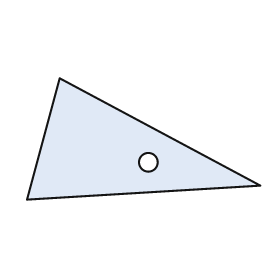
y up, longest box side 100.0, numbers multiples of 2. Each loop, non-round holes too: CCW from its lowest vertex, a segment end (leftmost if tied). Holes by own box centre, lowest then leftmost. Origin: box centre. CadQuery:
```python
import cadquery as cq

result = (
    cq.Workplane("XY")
    .moveTo(-50.0, -26.0)
    .lineTo(50.0, -20.0)
    .lineTo(-36.0, 26.0)
    .close()
    .moveTo(2.0, -10.0)
    .circle(4.0)
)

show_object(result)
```